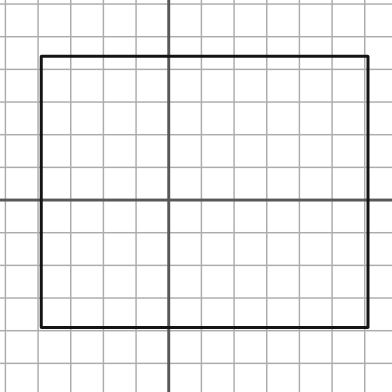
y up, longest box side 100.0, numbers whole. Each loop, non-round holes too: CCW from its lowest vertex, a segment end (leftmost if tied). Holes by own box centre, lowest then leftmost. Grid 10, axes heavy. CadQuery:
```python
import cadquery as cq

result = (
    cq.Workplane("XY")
    .moveTo(-39.0, -39.0)
    .lineTo(61.0, -39.0)
    .lineTo(61.0, 44.0)
    .lineTo(-39.0, 44.0)
    .close()
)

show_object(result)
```